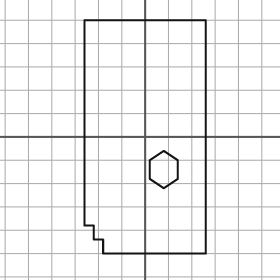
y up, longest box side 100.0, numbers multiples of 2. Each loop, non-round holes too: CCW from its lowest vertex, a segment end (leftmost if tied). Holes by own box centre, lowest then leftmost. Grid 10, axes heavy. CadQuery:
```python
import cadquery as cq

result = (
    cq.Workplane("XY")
    .moveTo(-18.0, -50.0)
    .lineTo(26.0, -50.0)
    .lineTo(26.0, 50.0)
    .lineTo(-26.0, 50.0)
    .lineTo(-26.0, -38.0)
    .lineTo(-22.0, -38.0)
    .lineTo(-22.0, -44.0)
    .lineTo(-18.0, -44.0)
    .close()
    .moveTo(8.0, -22.0)
    .lineTo(14.0, -18.0)
    .lineTo(14.0, -10.0)
    .lineTo(8.0, -6.0)
    .lineTo(2.0, -10.0)
    .lineTo(2.0, -18.0)
    .close()
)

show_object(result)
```